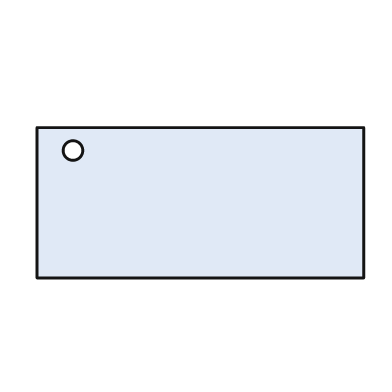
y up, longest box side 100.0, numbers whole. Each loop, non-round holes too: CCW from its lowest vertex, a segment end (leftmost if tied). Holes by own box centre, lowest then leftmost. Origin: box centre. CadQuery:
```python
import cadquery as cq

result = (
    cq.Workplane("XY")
    .moveTo(-50.0, -23.0)
    .lineTo(50.0, -23.0)
    .lineTo(50.0, 23.0)
    .lineTo(-50.0, 23.0)
    .close()
    .moveTo(-39.0, 16.0)
    .circle(3.0)
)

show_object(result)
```